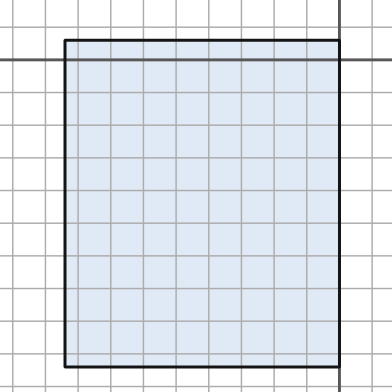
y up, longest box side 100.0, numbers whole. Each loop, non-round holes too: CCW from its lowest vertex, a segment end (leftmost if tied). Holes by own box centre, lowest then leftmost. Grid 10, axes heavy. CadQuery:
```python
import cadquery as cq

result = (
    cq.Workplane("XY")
    .moveTo(-84.0, -94.0)
    .lineTo(0.0, -94.0)
    .lineTo(0.0, 6.0)
    .lineTo(-84.0, 6.0)
    .close()
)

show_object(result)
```